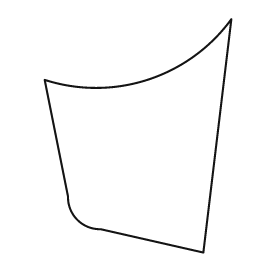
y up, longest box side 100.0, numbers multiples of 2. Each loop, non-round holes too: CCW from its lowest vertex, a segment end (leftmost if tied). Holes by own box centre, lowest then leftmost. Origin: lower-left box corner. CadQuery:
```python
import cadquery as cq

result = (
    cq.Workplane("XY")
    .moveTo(68.0, 0.0)
    .lineTo(80.0, 100.0)
    .threePointArc((44.0, 74.0), (0.0, 74.0))
    .lineTo(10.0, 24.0)
    .threePointArc((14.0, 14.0), (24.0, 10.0))
    .close()
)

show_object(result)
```